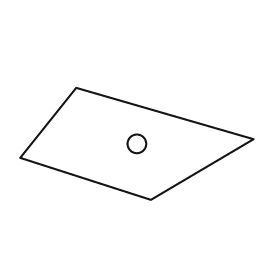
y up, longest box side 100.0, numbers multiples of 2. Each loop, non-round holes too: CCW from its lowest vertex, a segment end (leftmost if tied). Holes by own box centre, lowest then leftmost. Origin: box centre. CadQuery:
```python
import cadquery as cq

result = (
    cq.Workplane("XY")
    .moveTo(6.0, -24.0)
    .lineTo(50.0, 2.0)
    .lineTo(-26.0, 24.0)
    .lineTo(-50.0, -6.0)
    .close()
    .moveTo(0.0, 0.0)
    .circle(4.0)
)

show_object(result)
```